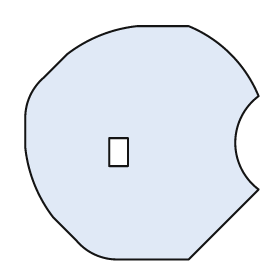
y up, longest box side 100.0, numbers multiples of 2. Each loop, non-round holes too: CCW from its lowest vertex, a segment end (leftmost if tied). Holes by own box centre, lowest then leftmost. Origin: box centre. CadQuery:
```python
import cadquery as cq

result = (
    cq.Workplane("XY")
    .moveTo(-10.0, -50.0)
    .lineTo(20.0, -50.0)
    .lineTo(50.0, -20.0)
    .threePointArc((40.0, 0.0), (50.0, 20.0))
    .threePointArc((38.0, 38.0), (20.0, 50.0))
    .lineTo(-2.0, 50.0)
    .threePointArc((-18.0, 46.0), (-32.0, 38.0))
    .lineTo(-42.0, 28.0)
    .threePointArc((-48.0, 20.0), (-50.0, 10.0))
    .lineTo(-50.0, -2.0)
    .threePointArc((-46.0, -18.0), (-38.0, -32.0))
    .lineTo(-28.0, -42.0)
    .threePointArc((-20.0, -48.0), (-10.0, -50.0))
    .close()
    .moveTo(-14.0, -10.0)
    .lineTo(-6.0, -10.0)
    .lineTo(-6.0, 2.0)
    .lineTo(-14.0, 2.0)
    .close()
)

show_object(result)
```